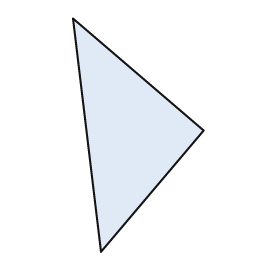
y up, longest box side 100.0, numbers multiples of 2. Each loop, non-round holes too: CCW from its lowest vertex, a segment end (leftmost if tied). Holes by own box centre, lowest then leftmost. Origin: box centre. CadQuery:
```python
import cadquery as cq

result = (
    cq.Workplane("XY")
    .moveTo(-16.0, -50.0)
    .lineTo(28.0, 2.0)
    .lineTo(-28.0, 50.0)
    .close()
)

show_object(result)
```